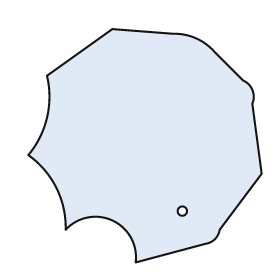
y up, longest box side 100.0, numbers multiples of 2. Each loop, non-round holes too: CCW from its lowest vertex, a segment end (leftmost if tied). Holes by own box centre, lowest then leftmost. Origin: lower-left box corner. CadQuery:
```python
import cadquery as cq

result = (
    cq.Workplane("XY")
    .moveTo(46.0, 0.0)
    .lineTo(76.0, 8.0)
    .threePointArc((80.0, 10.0), (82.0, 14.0))
    .lineTo(100.0, 38.0)
    .lineTo(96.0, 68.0)
    .threePointArc((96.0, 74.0), (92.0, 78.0))
    .lineTo(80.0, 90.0)
    .threePointArc((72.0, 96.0), (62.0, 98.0))
    .lineTo(36.0, 100.0)
    .lineTo(8.0, 80.0)
    .threePointArc((8.0, 62.0), (0.0, 46.0))
    .threePointArc((12.0, 32.0), (16.0, 14.0))
    .threePointArc((36.0, 18.0), (46.0, 0.0))
    .close()
    .moveTo(66.0, 22.0)
    .circle(2.0)
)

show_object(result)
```